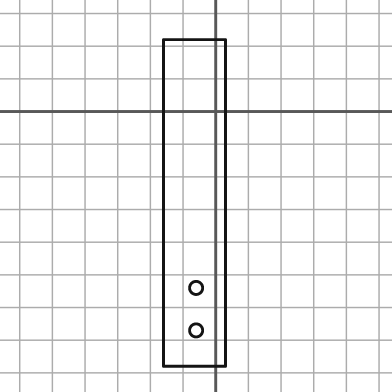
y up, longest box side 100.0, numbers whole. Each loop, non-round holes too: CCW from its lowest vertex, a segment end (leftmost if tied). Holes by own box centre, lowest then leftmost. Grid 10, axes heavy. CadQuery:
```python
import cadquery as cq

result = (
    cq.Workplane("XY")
    .moveTo(-16.0, -78.0)
    .lineTo(3.0, -78.0)
    .lineTo(3.0, 22.0)
    .lineTo(-16.0, 22.0)
    .close()
    .moveTo(-6.0, -67.0)
    .circle(2.0)
    .moveTo(-6.0, -54.0)
    .circle(2.0)
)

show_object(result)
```